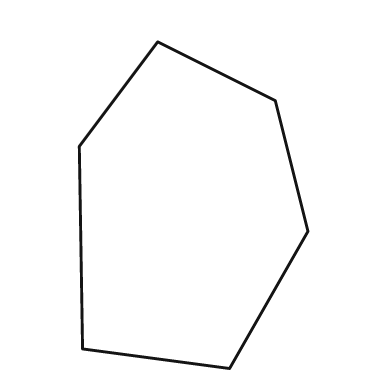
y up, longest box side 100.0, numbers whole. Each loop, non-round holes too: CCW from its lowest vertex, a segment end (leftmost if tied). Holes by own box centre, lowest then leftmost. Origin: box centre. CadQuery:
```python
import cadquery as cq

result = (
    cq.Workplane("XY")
    .moveTo(11.0, -50.0)
    .lineTo(35.0, -8.0)
    .lineTo(25.0, 32.0)
    .lineTo(-11.0, 50.0)
    .lineTo(-35.0, 18.0)
    .lineTo(-34.0, -44.0)
    .close()
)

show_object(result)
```